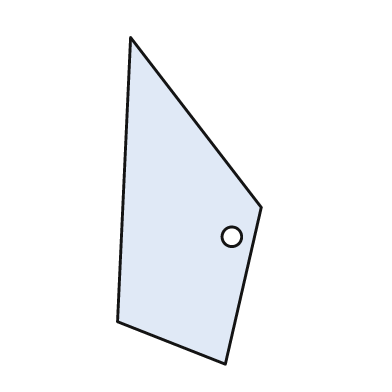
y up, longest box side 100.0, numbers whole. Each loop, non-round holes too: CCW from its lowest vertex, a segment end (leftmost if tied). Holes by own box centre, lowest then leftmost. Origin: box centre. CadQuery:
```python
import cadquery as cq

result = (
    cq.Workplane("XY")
    .moveTo(11.0, -50.0)
    .lineTo(22.0, -2.0)
    .lineTo(-18.0, 50.0)
    .lineTo(-22.0, -37.0)
    .close()
    .moveTo(13.0, -11.0)
    .circle(3.0)
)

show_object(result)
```